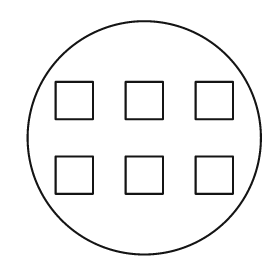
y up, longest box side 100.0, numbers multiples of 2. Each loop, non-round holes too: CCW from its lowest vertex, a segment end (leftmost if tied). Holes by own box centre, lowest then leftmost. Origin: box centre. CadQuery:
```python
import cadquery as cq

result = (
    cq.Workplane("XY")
    .moveTo(0.0, 0.0)
    .circle(50.0)
    .moveTo(-38.0, -24.0)
    .lineTo(-22.0, -24.0)
    .lineTo(-22.0, -8.0)
    .lineTo(-38.0, -8.0)
    .close()
    .moveTo(-8.0, -24.0)
    .lineTo(8.0, -24.0)
    .lineTo(8.0, -8.0)
    .lineTo(-8.0, -8.0)
    .close()
    .moveTo(22.0, -24.0)
    .lineTo(38.0, -24.0)
    .lineTo(38.0, -8.0)
    .lineTo(22.0, -8.0)
    .close()
    .moveTo(-38.0, 8.0)
    .lineTo(-22.0, 8.0)
    .lineTo(-22.0, 24.0)
    .lineTo(-38.0, 24.0)
    .close()
    .moveTo(-8.0, 8.0)
    .lineTo(8.0, 8.0)
    .lineTo(8.0, 24.0)
    .lineTo(-8.0, 24.0)
    .close()
    .moveTo(22.0, 8.0)
    .lineTo(38.0, 8.0)
    .lineTo(38.0, 24.0)
    .lineTo(22.0, 24.0)
    .close()
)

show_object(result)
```